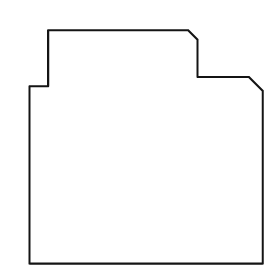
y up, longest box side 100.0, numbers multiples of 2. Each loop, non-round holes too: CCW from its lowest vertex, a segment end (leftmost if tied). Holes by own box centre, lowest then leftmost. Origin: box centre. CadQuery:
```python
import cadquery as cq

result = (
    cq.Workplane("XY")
    .moveTo(-50.0, -50.0)
    .lineTo(50.0, -50.0)
    .lineTo(50.0, 24.0)
    .lineTo(44.0, 30.0)
    .lineTo(22.0, 30.0)
    .lineTo(22.0, 46.0)
    .lineTo(18.0, 50.0)
    .lineTo(-42.0, 50.0)
    .lineTo(-42.0, 26.0)
    .lineTo(-50.0, 26.0)
    .close()
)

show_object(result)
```